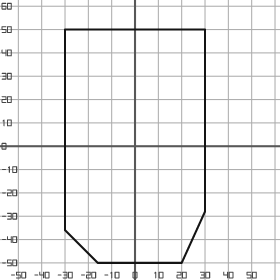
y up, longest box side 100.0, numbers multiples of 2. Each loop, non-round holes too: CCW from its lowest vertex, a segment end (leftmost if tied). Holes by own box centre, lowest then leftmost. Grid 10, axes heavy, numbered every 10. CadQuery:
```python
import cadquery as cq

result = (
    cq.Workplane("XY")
    .moveTo(-16.0, -50.0)
    .lineTo(20.0, -50.0)
    .lineTo(30.0, -28.0)
    .lineTo(30.0, 50.0)
    .lineTo(-30.0, 50.0)
    .lineTo(-30.0, -36.0)
    .close()
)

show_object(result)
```